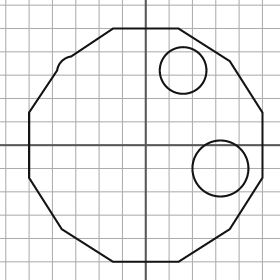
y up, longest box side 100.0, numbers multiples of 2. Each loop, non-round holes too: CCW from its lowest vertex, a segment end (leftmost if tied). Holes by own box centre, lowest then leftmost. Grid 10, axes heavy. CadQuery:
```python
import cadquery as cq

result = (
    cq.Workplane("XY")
    .moveTo(-14.0, -50.0)
    .lineTo(14.0, -50.0)
    .lineTo(36.0, -36.0)
    .lineTo(50.0, -14.0)
    .lineTo(50.0, 14.0)
    .lineTo(36.0, 36.0)
    .lineTo(14.0, 50.0)
    .lineTo(-14.0, 50.0)
    .lineTo(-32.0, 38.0)
    .threePointArc((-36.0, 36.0), (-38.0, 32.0))
    .lineTo(-50.0, 14.0)
    .lineTo(-50.0, -14.0)
    .lineTo(-36.0, -36.0)
    .close()
    .moveTo(32.0, -10.0)
    .circle(12.0)
    .moveTo(16.0, 32.0)
    .circle(10.0)
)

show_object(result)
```